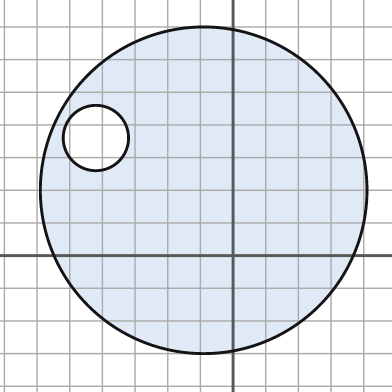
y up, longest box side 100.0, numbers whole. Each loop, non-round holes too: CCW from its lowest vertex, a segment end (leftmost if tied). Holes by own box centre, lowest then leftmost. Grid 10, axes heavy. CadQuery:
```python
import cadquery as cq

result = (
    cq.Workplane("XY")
    .moveTo(-9.0, 20.0)
    .circle(50.0)
    .moveTo(-42.0, 36.0)
    .circle(10.0)
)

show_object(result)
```